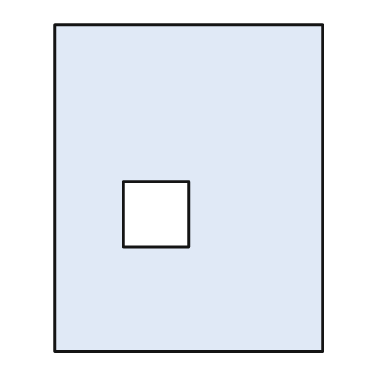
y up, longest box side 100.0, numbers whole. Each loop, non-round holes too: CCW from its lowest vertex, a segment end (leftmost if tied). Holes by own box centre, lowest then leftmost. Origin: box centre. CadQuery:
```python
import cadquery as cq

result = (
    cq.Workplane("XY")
    .moveTo(-41.0, -50.0)
    .lineTo(41.0, -50.0)
    .lineTo(41.0, 50.0)
    .lineTo(-41.0, 50.0)
    .close()
    .moveTo(-20.0, -18.0)
    .lineTo(0.0, -18.0)
    .lineTo(0.0, 2.0)
    .lineTo(-20.0, 2.0)
    .close()
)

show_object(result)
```